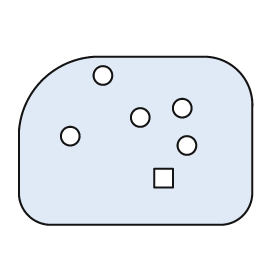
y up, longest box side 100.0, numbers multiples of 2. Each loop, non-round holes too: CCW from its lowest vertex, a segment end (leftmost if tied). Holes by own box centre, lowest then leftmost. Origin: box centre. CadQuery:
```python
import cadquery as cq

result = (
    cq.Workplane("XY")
    .moveTo(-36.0, -36.0)
    .lineTo(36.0, -36.0)
    .threePointArc((46.0, -32.0), (50.0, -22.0))
    .lineTo(50.0, 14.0)
    .threePointArc((44.0, 30.0), (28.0, 36.0))
    .lineTo(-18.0, 36.0)
    .threePointArc((-40.0, 26.0), (-50.0, 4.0))
    .lineTo(-50.0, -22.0)
    .threePointArc((-46.0, -32.0), (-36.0, -36.0))
    .close()
    .moveTo(8.0, -20.0)
    .lineTo(16.0, -20.0)
    .lineTo(16.0, -12.0)
    .lineTo(8.0, -12.0)
    .close()
    .moveTo(22.0, -2.0)
    .circle(4.0)
    .moveTo(-28.0, 2.0)
    .circle(4.0)
    .moveTo(2.0, 10.0)
    .circle(4.0)
    .moveTo(20.0, 14.0)
    .circle(4.0)
    .moveTo(-14.0, 28.0)
    .circle(4.0)
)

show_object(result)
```